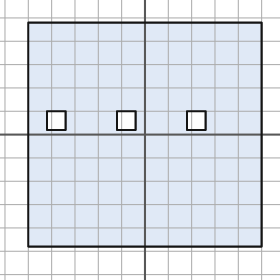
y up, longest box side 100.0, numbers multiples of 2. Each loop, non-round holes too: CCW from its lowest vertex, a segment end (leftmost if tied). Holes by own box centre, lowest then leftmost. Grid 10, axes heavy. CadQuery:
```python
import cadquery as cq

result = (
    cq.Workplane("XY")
    .moveTo(-50.0, -48.0)
    .lineTo(50.0, -48.0)
    .lineTo(50.0, 48.0)
    .lineTo(-50.0, 48.0)
    .close()
    .moveTo(-42.0, 2.0)
    .lineTo(-34.0, 2.0)
    .lineTo(-34.0, 10.0)
    .lineTo(-42.0, 10.0)
    .close()
    .moveTo(-12.0, 2.0)
    .lineTo(-4.0, 2.0)
    .lineTo(-4.0, 10.0)
    .lineTo(-12.0, 10.0)
    .close()
    .moveTo(18.0, 2.0)
    .lineTo(26.0, 2.0)
    .lineTo(26.0, 10.0)
    .lineTo(18.0, 10.0)
    .close()
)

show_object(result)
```